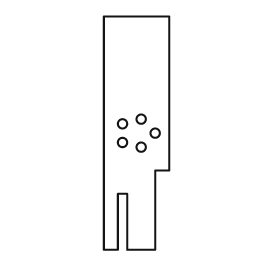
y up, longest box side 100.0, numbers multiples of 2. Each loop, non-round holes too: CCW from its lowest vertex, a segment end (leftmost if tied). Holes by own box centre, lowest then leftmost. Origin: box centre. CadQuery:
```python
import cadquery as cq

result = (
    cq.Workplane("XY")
    .moveTo(-14.0, -50.0)
    .lineTo(-8.0, -50.0)
    .lineTo(-8.0, -26.0)
    .lineTo(-4.0, -26.0)
    .lineTo(-4.0, -50.0)
    .lineTo(8.0, -50.0)
    .lineTo(8.0, -16.0)
    .lineTo(14.0, -16.0)
    .lineTo(14.0, 50.0)
    .lineTo(-14.0, 50.0)
    .close()
    .moveTo(2.0, -6.0)
    .circle(2.0)
    .moveTo(-6.0, -4.0)
    .circle(2.0)
    .moveTo(8.0, 0.0)
    .circle(2.0)
    .moveTo(-6.0, 4.0)
    .circle(2.0)
    .moveTo(2.0, 6.0)
    .circle(2.0)
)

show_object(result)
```